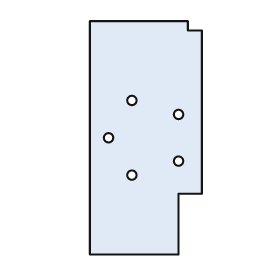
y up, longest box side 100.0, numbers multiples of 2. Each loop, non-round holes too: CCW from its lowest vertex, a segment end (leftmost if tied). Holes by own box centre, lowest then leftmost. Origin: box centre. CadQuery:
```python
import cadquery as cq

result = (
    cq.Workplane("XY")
    .moveTo(-24.0, -50.0)
    .lineTo(14.0, -50.0)
    .lineTo(14.0, -24.0)
    .lineTo(24.0, -24.0)
    .lineTo(24.0, 46.0)
    .lineTo(18.0, 46.0)
    .lineTo(18.0, 50.0)
    .lineTo(-24.0, 50.0)
    .close()
    .moveTo(-6.0, -16.0)
    .circle(2.0)
    .moveTo(14.0, -10.0)
    .circle(2.0)
    .moveTo(-16.0, 0.0)
    .circle(2.0)
    .moveTo(14.0, 10.0)
    .circle(2.0)
    .moveTo(-6.0, 16.0)
    .circle(2.0)
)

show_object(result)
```